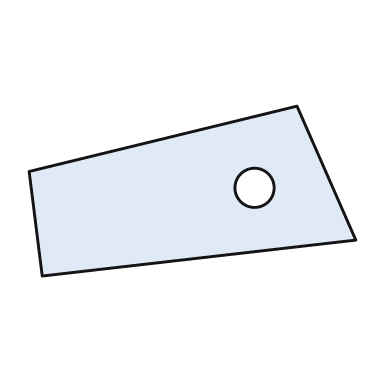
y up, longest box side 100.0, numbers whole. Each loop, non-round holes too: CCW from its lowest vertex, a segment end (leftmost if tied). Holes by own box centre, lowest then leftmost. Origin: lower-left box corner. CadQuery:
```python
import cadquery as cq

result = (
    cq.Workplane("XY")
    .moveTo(4.0, 0.0)
    .lineTo(100.0, 11.0)
    .lineTo(82.0, 52.0)
    .lineTo(0.0, 32.0)
    .close()
    .moveTo(69.0, 27.0)
    .circle(6.0)
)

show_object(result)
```